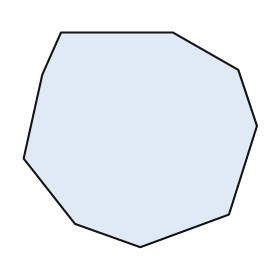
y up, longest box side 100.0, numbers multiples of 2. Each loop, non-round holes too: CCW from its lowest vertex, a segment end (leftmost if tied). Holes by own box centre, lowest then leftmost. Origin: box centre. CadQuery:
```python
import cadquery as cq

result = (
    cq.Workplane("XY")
    .moveTo(0.0, -46.0)
    .lineTo(38.0, -32.0)
    .lineTo(50.0, 6.0)
    .lineTo(42.0, 30.0)
    .lineTo(14.0, 46.0)
    .lineTo(-34.0, 46.0)
    .lineTo(-42.0, 28.0)
    .lineTo(-50.0, -8.0)
    .lineTo(-28.0, -36.0)
    .close()
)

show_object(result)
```